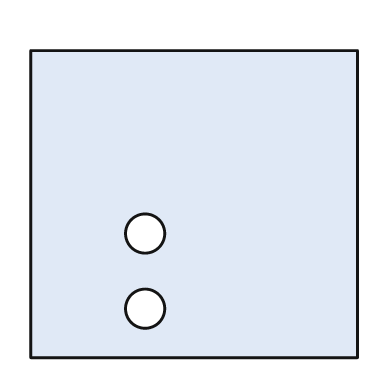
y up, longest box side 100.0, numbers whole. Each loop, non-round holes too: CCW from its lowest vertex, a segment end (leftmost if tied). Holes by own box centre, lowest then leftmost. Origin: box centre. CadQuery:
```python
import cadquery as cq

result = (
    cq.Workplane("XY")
    .moveTo(-50.0, -47.0)
    .lineTo(50.0, -47.0)
    .lineTo(50.0, 47.0)
    .lineTo(-50.0, 47.0)
    .close()
    .moveTo(-15.0, -32.0)
    .circle(6.0)
    .moveTo(-15.0, -9.0)
    .circle(6.0)
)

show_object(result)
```